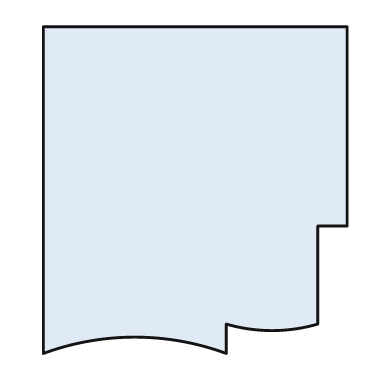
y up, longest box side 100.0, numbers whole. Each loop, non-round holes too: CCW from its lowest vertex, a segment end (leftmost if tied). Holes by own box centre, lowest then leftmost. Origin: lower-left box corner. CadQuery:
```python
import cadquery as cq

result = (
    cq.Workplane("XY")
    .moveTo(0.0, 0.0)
    .threePointArc((28.0, 5.0), (56.0, 0.0))
    .lineTo(56.0, 9.0)
    .threePointArc((70.0, 7.0), (84.0, 9.0))
    .lineTo(84.0, 39.0)
    .lineTo(93.0, 39.0)
    .lineTo(93.0, 100.0)
    .lineTo(0.0, 100.0)
    .close()
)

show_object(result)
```